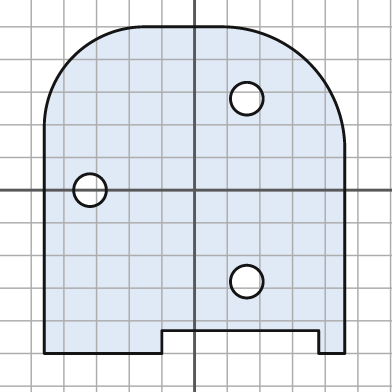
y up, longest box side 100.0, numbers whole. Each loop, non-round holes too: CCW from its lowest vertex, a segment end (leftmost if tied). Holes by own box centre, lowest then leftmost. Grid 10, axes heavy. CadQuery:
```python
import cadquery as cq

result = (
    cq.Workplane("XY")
    .moveTo(-46.0, -50.0)
    .lineTo(-10.0, -50.0)
    .lineTo(-10.0, -43.0)
    .lineTo(38.0, -43.0)
    .lineTo(38.0, -50.0)
    .lineTo(46.0, -50.0)
    .lineTo(46.0, 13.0)
    .threePointArc((35.0, 39.0), (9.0, 50.0))
    .lineTo(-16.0, 50.0)
    .threePointArc((-37.0, 41.0), (-46.0, 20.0))
    .close()
    .moveTo(16.0, -28.0)
    .circle(5.0)
    .moveTo(-32.0, 0.0)
    .circle(5.0)
    .moveTo(16.0, 28.0)
    .circle(5.0)
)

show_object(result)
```